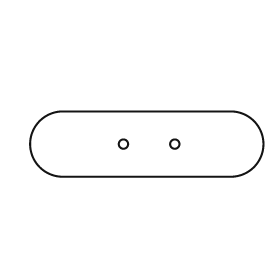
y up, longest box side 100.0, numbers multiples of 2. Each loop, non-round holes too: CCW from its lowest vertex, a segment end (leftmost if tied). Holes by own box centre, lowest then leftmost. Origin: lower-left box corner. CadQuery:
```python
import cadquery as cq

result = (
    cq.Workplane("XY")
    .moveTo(14.0, 0.0)
    .lineTo(86.0, 0.0)
    .threePointArc((100.0, 14.0), (86.0, 28.0))
    .lineTo(14.0, 28.0)
    .threePointArc((0.0, 14.0), (14.0, 0.0))
    .close()
    .moveTo(40.0, 14.0)
    .circle(2.0)
    .moveTo(62.0, 14.0)
    .circle(2.0)
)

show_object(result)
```